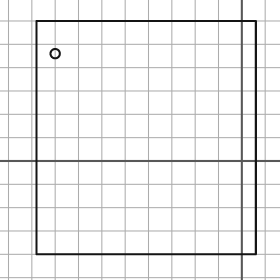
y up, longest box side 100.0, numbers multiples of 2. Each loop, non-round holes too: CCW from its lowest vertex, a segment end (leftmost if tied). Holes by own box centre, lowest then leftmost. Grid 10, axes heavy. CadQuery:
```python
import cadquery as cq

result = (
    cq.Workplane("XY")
    .moveTo(-88.0, -40.0)
    .lineTo(6.0, -40.0)
    .lineTo(6.0, 60.0)
    .lineTo(-88.0, 60.0)
    .close()
    .moveTo(-80.0, 46.0)
    .circle(2.0)
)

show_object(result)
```